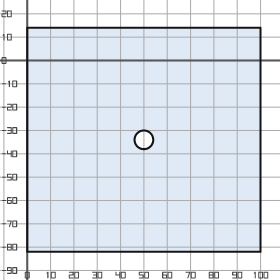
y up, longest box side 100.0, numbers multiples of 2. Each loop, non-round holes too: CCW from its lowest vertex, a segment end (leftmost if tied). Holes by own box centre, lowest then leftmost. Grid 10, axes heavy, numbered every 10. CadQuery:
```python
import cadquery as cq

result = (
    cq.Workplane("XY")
    .moveTo(0.0, -82.0)
    .lineTo(100.0, -82.0)
    .lineTo(100.0, 14.0)
    .lineTo(0.0, 14.0)
    .close()
    .moveTo(50.0, -34.0)
    .circle(4.0)
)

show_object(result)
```